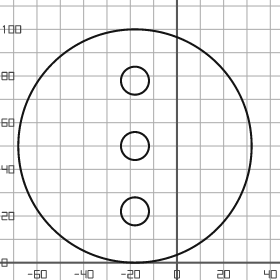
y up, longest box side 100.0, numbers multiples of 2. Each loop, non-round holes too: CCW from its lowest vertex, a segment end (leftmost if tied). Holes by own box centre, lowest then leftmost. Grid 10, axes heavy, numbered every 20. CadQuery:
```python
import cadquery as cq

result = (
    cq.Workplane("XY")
    .moveTo(-18.0, 50.0)
    .circle(50.0)
    .moveTo(-18.0, 22.0)
    .circle(6.0)
    .moveTo(-18.0, 50.0)
    .circle(6.0)
    .moveTo(-18.0, 78.0)
    .circle(6.0)
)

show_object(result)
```